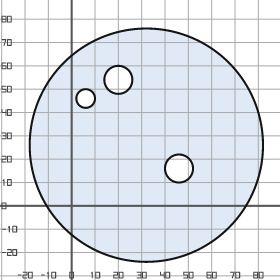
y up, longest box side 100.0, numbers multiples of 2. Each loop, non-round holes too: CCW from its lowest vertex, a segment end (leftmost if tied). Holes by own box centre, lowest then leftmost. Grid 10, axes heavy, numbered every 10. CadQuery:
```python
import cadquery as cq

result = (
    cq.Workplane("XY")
    .moveTo(32.0, 26.0)
    .circle(50.0)
    .moveTo(46.0, 16.0)
    .circle(6.0)
    .moveTo(6.0, 46.0)
    .circle(4.0)
    .moveTo(20.0, 54.0)
    .circle(6.0)
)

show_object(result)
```